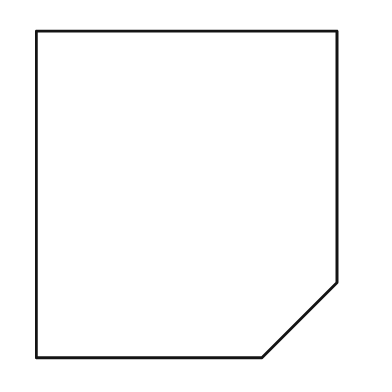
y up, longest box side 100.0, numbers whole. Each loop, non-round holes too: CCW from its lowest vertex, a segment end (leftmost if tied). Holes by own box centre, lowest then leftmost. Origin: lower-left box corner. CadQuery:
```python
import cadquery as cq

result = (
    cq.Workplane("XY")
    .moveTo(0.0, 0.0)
    .lineTo(69.0, 0.0)
    .lineTo(92.0, 23.0)
    .lineTo(92.0, 100.0)
    .lineTo(0.0, 100.0)
    .close()
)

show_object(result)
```